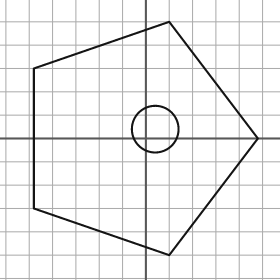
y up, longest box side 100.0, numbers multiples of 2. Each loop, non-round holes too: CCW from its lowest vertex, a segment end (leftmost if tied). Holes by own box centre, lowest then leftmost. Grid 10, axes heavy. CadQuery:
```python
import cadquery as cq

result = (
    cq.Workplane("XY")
    .moveTo(10.0, -50.0)
    .lineTo(48.0, 0.0)
    .lineTo(10.0, 50.0)
    .lineTo(-48.0, 30.0)
    .lineTo(-48.0, -30.0)
    .close()
    .moveTo(4.0, 4.0)
    .circle(10.0)
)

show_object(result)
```